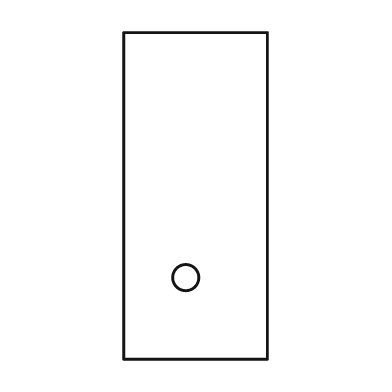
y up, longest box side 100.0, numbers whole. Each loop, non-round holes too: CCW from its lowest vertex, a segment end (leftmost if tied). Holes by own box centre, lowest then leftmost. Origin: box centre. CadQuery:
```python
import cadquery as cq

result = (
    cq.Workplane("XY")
    .moveTo(-22.0, -50.0)
    .lineTo(22.0, -50.0)
    .lineTo(22.0, 50.0)
    .lineTo(-22.0, 50.0)
    .close()
    .moveTo(-3.0, -25.0)
    .circle(4.0)
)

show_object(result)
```